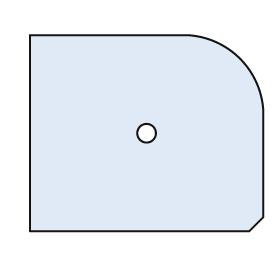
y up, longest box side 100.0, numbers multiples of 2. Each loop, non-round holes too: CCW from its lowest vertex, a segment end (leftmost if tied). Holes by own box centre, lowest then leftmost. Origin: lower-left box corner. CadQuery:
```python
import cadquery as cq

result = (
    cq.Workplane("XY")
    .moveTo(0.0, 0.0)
    .lineTo(94.0, 0.0)
    .lineTo(100.0, 6.0)
    .lineTo(100.0, 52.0)
    .threePointArc((90.0, 74.0), (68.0, 84.0))
    .lineTo(0.0, 84.0)
    .close()
    .moveTo(50.0, 42.0)
    .circle(4.0)
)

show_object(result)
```